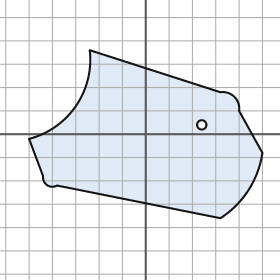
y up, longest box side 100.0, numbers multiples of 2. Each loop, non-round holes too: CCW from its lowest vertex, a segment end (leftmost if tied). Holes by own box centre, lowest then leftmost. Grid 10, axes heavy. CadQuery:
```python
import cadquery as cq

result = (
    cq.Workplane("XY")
    .moveTo(32.0, -36.0)
    .threePointArc((44.0, -24.0), (50.0, -8.0))
    .lineTo(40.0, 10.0)
    .threePointArc((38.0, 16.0), (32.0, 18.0))
    .lineTo(-24.0, 36.0)
    .threePointArc((-30.0, 12.0), (-50.0, -2.0))
    .lineTo(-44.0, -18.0)
    .threePointArc((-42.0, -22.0), (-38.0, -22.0))
    .close()
    .moveTo(24.0, 4.0)
    .circle(2.0)
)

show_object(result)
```